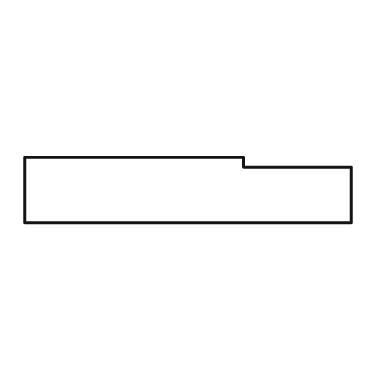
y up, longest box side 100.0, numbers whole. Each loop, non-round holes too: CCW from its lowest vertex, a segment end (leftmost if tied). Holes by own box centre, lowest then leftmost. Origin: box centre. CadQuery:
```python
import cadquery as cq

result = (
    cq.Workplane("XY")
    .moveTo(-50.0, -10.0)
    .lineTo(50.0, -10.0)
    .lineTo(50.0, 7.0)
    .lineTo(17.0, 7.0)
    .lineTo(17.0, 10.0)
    .lineTo(-50.0, 10.0)
    .close()
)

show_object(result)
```